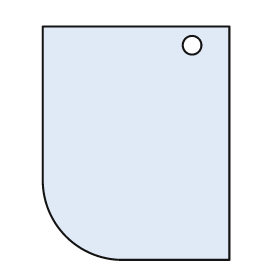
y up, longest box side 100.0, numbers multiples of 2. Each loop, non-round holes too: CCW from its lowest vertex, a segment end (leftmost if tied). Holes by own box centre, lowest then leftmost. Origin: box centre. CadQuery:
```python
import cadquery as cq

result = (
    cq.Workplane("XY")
    .moveTo(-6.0, -50.0)
    .lineTo(40.0, -50.0)
    .lineTo(40.0, 50.0)
    .lineTo(-40.0, 50.0)
    .lineTo(-40.0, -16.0)
    .threePointArc((-30.0, -40.0), (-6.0, -50.0))
    .close()
    .moveTo(24.0, 42.0)
    .circle(4.0)
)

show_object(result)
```